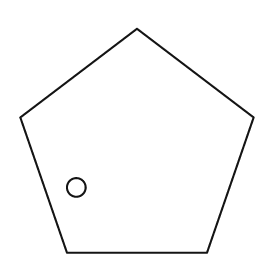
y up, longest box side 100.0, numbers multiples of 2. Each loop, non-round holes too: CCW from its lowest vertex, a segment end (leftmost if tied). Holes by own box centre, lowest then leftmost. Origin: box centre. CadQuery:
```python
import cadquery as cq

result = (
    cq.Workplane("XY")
    .moveTo(-30.0, -48.0)
    .lineTo(30.0, -48.0)
    .lineTo(50.0, 10.0)
    .lineTo(0.0, 48.0)
    .lineTo(-50.0, 10.0)
    .close()
    .moveTo(-26.0, -20.0)
    .circle(4.0)
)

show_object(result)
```